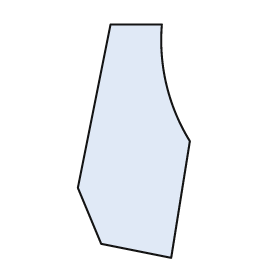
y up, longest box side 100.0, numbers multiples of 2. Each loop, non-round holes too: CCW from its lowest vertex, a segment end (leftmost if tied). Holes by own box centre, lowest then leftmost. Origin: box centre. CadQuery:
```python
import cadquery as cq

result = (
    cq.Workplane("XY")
    .moveTo(16.0, -50.0)
    .lineTo(24.0, 0.0)
    .threePointArc((14.0, 24.0), (12.0, 50.0))
    .lineTo(-10.0, 50.0)
    .lineTo(-24.0, -20.0)
    .lineTo(-14.0, -44.0)
    .close()
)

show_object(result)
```